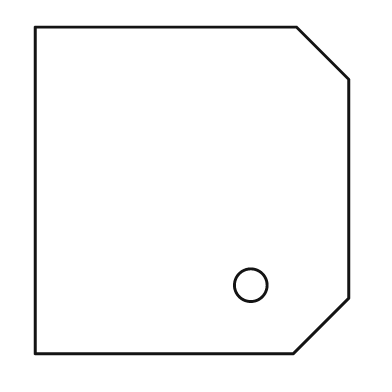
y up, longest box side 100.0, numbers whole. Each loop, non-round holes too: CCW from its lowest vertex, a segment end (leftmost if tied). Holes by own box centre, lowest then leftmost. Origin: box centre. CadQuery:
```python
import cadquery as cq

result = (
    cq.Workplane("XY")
    .moveTo(-48.0, -50.0)
    .lineTo(31.0, -50.0)
    .lineTo(48.0, -33.0)
    .lineTo(48.0, 34.0)
    .lineTo(32.0, 50.0)
    .lineTo(-48.0, 50.0)
    .close()
    .moveTo(18.0, -29.0)
    .circle(5.0)
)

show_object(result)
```